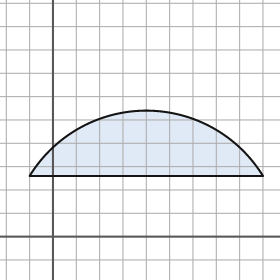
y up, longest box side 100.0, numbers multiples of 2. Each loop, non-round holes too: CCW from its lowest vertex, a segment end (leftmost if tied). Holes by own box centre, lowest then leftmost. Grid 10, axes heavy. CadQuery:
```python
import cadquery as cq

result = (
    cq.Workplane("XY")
    .moveTo(-10.0, 26.0)
    .lineTo(90.0, 26.0)
    .threePointArc((40.0, 54.0), (-10.0, 26.0))
    .close()
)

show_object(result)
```